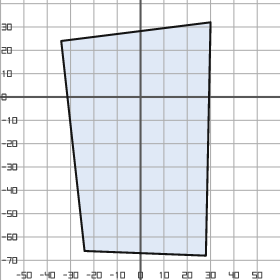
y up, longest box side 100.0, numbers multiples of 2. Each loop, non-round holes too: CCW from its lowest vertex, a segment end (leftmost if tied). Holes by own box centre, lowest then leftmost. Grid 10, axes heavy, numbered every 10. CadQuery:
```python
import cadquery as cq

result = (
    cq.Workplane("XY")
    .moveTo(28.0, -68.0)
    .lineTo(30.0, 32.0)
    .lineTo(-34.0, 24.0)
    .lineTo(-24.0, -66.0)
    .close()
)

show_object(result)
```